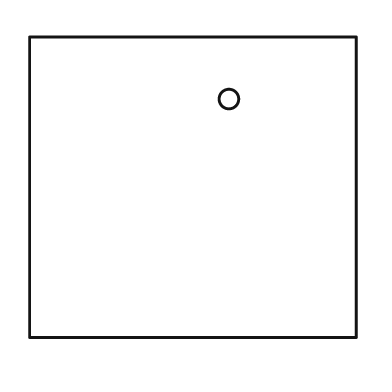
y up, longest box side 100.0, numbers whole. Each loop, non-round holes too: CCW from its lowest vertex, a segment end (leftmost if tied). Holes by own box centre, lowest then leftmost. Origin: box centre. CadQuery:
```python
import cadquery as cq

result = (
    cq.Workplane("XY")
    .moveTo(-50.0, -46.0)
    .lineTo(50.0, -46.0)
    .lineTo(50.0, 46.0)
    .lineTo(-50.0, 46.0)
    .close()
    .moveTo(11.0, 27.0)
    .circle(3.0)
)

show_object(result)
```